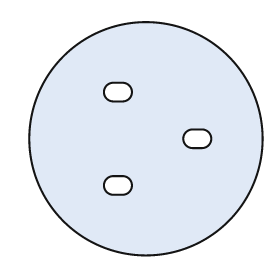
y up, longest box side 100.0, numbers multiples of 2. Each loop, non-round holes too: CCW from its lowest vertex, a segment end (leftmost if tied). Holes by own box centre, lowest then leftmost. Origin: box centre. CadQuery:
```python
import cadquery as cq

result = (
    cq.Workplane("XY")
    .moveTo(0.0, 0.0)
    .circle(50.0)
    .moveTo(-14.0, -24.0)
    .lineTo(-10.0, -24.0)
    .threePointArc((-6.0, -20.0), (-10.0, -16.0))
    .lineTo(-14.0, -16.0)
    .threePointArc((-18.0, -20.0), (-14.0, -24.0))
    .close()
    .moveTo(20.0, -4.0)
    .lineTo(24.0, -4.0)
    .threePointArc((28.0, 0.0), (24.0, 4.0))
    .lineTo(20.0, 4.0)
    .threePointArc((16.0, 0.0), (20.0, -4.0))
    .close()
    .moveTo(-14.0, 16.0)
    .lineTo(-10.0, 16.0)
    .threePointArc((-6.0, 20.0), (-10.0, 24.0))
    .lineTo(-14.0, 24.0)
    .threePointArc((-18.0, 20.0), (-14.0, 16.0))
    .close()
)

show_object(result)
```